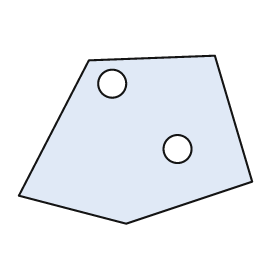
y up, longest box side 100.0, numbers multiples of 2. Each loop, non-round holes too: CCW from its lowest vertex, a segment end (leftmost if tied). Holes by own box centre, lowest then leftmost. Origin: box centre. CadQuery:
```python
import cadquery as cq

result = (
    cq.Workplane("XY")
    .moveTo(-4.0, -36.0)
    .lineTo(50.0, -18.0)
    .lineTo(34.0, 36.0)
    .lineTo(-20.0, 34.0)
    .lineTo(-50.0, -24.0)
    .close()
    .moveTo(18.0, -4.0)
    .circle(6.0)
    .moveTo(-10.0, 24.0)
    .circle(6.0)
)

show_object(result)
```